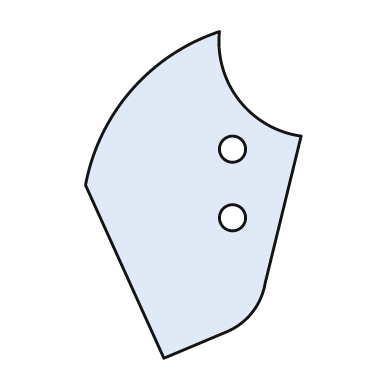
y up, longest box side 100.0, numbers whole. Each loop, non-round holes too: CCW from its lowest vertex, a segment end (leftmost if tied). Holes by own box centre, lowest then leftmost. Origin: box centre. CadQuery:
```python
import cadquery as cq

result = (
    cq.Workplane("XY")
    .moveTo(-9.0, -50.0)
    .lineTo(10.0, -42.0)
    .threePointArc((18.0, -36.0), (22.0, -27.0))
    .lineTo(33.0, 18.0)
    .threePointArc((14.0, 29.0), (8.0, 50.0))
    .threePointArc((-19.0, 32.0), (-33.0, 3.0))
    .close()
    .moveTo(12.0, -7.0)
    .circle(4.0)
    .moveTo(12.0, 14.0)
    .circle(4.0)
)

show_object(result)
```